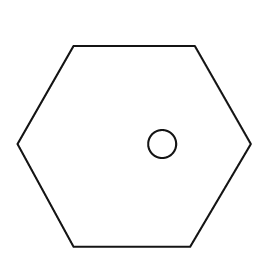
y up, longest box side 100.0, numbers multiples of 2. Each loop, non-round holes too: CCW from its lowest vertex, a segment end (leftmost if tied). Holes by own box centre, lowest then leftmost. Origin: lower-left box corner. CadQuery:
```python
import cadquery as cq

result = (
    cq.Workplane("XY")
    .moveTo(24.0, 0.0)
    .lineTo(74.0, 0.0)
    .lineTo(100.0, 44.0)
    .lineTo(76.0, 86.0)
    .lineTo(24.0, 86.0)
    .lineTo(0.0, 44.0)
    .close()
    .moveTo(62.0, 44.0)
    .circle(6.0)
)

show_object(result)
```